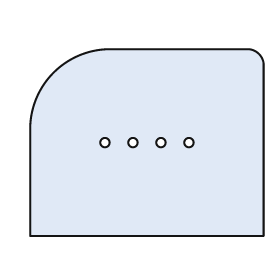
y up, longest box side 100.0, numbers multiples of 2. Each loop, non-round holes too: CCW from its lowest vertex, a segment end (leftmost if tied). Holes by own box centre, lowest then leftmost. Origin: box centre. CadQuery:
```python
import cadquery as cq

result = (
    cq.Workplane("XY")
    .moveTo(-50.0, -40.0)
    .lineTo(50.0, -40.0)
    .lineTo(50.0, 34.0)
    .threePointArc((48.0, 38.0), (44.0, 40.0))
    .lineTo(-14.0, 40.0)
    .threePointArc((-40.0, 30.0), (-50.0, 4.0))
    .close()
    .moveTo(-18.0, 0.0)
    .circle(2.0)
    .moveTo(-6.0, 0.0)
    .circle(2.0)
    .moveTo(6.0, 0.0)
    .circle(2.0)
    .moveTo(18.0, 0.0)
    .circle(2.0)
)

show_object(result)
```